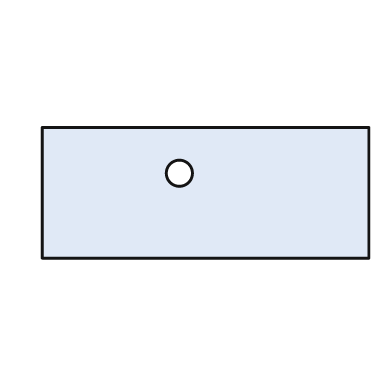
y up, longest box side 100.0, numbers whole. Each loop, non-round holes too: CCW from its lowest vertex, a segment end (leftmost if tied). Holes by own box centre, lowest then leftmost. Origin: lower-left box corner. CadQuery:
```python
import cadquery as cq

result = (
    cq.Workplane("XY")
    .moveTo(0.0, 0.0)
    .lineTo(100.0, 0.0)
    .lineTo(100.0, 40.0)
    .lineTo(0.0, 40.0)
    .close()
    .moveTo(42.0, 26.0)
    .circle(4.0)
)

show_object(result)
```